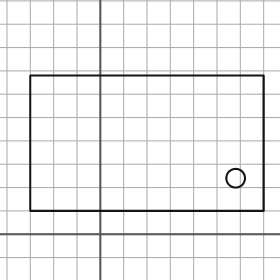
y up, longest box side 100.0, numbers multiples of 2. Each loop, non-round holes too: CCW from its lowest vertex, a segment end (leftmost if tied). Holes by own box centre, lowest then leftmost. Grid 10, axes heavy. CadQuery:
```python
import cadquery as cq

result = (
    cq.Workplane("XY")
    .moveTo(-30.0, 10.0)
    .lineTo(70.0, 10.0)
    .lineTo(70.0, 68.0)
    .lineTo(-30.0, 68.0)
    .close()
    .moveTo(58.0, 24.0)
    .circle(4.0)
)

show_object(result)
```